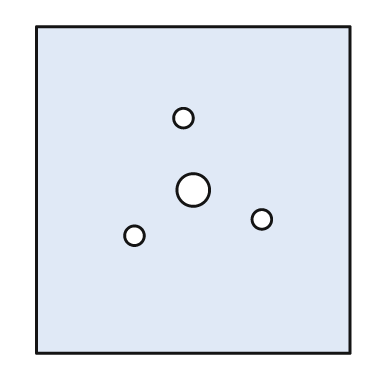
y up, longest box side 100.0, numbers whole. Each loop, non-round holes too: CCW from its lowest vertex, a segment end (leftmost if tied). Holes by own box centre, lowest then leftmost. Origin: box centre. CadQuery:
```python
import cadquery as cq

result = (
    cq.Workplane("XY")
    .moveTo(-48.0, -50.0)
    .lineTo(48.0, -50.0)
    .lineTo(48.0, 50.0)
    .lineTo(-48.0, 50.0)
    .close()
    .moveTo(-18.0, -14.0)
    .circle(3.0)
    .moveTo(21.0, -9.0)
    .circle(3.0)
    .moveTo(0.0, 0.0)
    .circle(5.0)
    .moveTo(-3.0, 22.0)
    .circle(3.0)
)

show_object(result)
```